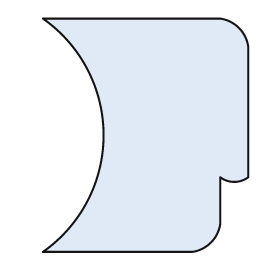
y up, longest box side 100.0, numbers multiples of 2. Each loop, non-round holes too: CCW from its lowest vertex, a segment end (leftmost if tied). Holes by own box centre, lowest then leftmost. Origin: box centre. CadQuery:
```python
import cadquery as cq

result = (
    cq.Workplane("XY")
    .moveTo(-44.0, -50.0)
    .lineTo(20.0, -50.0)
    .threePointArc((28.0, -46.0), (32.0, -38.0))
    .lineTo(32.0, -18.0)
    .threePointArc((38.0, -20.0), (44.0, -18.0))
    .lineTo(44.0, 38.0)
    .threePointArc((40.0, 46.0), (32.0, 50.0))
    .lineTo(-44.0, 50.0)
    .threePointArc((-18.0, 0.0), (-44.0, -50.0))
    .close()
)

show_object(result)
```